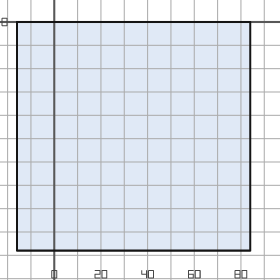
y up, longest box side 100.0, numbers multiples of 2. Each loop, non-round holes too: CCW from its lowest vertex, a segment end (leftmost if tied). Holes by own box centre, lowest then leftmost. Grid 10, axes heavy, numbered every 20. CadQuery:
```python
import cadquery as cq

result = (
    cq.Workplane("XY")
    .moveTo(-16.0, -98.0)
    .lineTo(84.0, -98.0)
    .lineTo(84.0, 0.0)
    .lineTo(-16.0, 0.0)
    .close()
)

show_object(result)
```